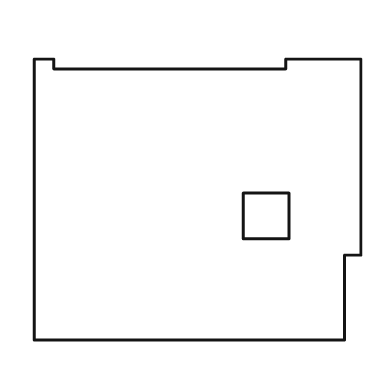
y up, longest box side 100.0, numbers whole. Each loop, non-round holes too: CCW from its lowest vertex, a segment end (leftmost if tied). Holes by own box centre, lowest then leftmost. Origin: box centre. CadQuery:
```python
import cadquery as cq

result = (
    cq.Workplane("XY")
    .moveTo(-50.0, -43.0)
    .lineTo(45.0, -43.0)
    .lineTo(45.0, -17.0)
    .lineTo(50.0, -17.0)
    .lineTo(50.0, 43.0)
    .lineTo(27.0, 43.0)
    .lineTo(27.0, 40.0)
    .lineTo(-44.0, 40.0)
    .lineTo(-44.0, 43.0)
    .lineTo(-50.0, 43.0)
    .close()
    .moveTo(14.0, -12.0)
    .lineTo(28.0, -12.0)
    .lineTo(28.0, 2.0)
    .lineTo(14.0, 2.0)
    .close()
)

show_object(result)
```